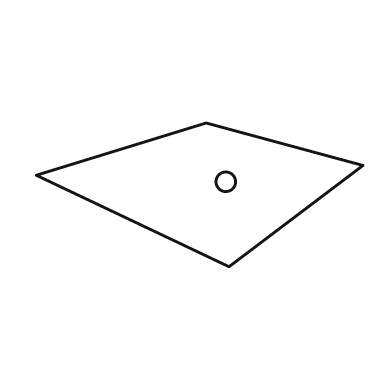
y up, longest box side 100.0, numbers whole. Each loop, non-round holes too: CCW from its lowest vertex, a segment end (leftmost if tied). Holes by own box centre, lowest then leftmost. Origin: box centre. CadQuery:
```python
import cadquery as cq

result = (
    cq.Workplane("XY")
    .moveTo(9.0, -22.0)
    .lineTo(50.0, 9.0)
    .lineTo(2.0, 22.0)
    .lineTo(-50.0, 6.0)
    .close()
    .moveTo(8.0, 4.0)
    .circle(3.0)
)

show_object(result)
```